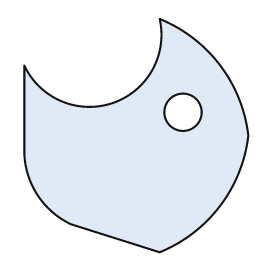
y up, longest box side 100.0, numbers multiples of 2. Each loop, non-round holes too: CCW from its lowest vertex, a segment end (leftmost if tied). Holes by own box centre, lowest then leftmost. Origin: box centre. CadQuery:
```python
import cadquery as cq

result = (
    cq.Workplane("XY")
    .moveTo(10.0, -50.0)
    .threePointArc((36.0, -30.0), (48.0, 0.0))
    .threePointArc((36.0, 30.0), (10.0, 50.0))
    .threePointArc((-10.0, 14.0), (-48.0, 30.0))
    .lineTo(-48.0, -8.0)
    .threePointArc((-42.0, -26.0), (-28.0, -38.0))
    .close()
    .moveTo(20.0, 10.0)
    .circle(8.0)
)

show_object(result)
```